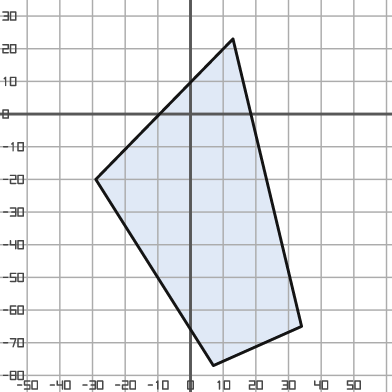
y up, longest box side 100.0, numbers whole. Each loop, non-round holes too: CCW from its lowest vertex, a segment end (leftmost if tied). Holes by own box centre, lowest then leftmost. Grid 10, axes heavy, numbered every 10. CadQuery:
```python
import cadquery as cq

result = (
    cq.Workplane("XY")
    .moveTo(7.0, -77.0)
    .lineTo(34.0, -65.0)
    .lineTo(13.0, 23.0)
    .lineTo(-29.0, -20.0)
    .close()
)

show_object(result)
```